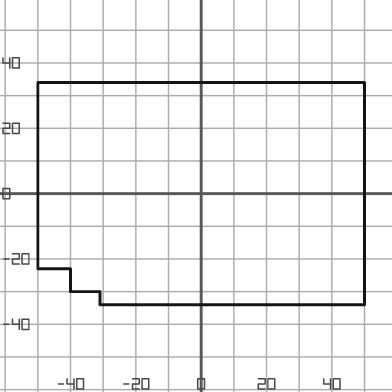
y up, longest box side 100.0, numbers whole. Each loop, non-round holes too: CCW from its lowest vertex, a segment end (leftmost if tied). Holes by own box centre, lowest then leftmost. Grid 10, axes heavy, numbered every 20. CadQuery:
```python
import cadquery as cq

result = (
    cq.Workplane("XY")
    .moveTo(-31.0, -34.0)
    .lineTo(50.0, -34.0)
    .lineTo(50.0, 34.0)
    .lineTo(-50.0, 34.0)
    .lineTo(-50.0, -23.0)
    .lineTo(-40.0, -23.0)
    .lineTo(-40.0, -30.0)
    .lineTo(-31.0, -30.0)
    .close()
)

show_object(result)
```